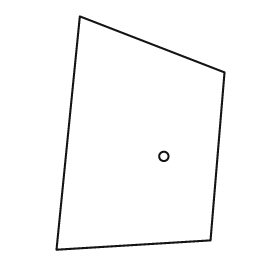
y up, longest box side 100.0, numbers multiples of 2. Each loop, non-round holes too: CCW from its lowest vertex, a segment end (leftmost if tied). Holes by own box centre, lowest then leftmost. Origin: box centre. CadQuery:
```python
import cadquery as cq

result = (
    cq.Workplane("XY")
    .moveTo(-36.0, -50.0)
    .lineTo(30.0, -46.0)
    .lineTo(36.0, 26.0)
    .lineTo(-26.0, 50.0)
    .close()
    .moveTo(10.0, -10.0)
    .circle(2.0)
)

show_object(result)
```